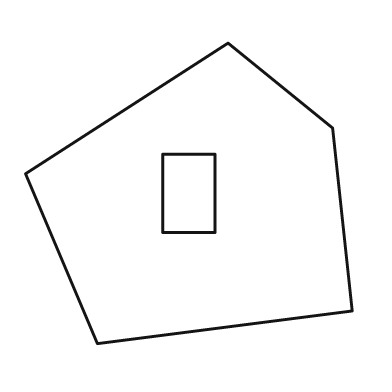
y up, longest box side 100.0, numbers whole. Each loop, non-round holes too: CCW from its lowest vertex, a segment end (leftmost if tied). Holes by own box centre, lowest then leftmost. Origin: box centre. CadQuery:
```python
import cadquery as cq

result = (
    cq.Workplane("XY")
    .moveTo(-28.0, -46.0)
    .lineTo(50.0, -36.0)
    .lineTo(44.0, 20.0)
    .lineTo(12.0, 46.0)
    .lineTo(-50.0, 6.0)
    .close()
    .moveTo(-8.0, -12.0)
    .lineTo(8.0, -12.0)
    .lineTo(8.0, 12.0)
    .lineTo(-8.0, 12.0)
    .close()
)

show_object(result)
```